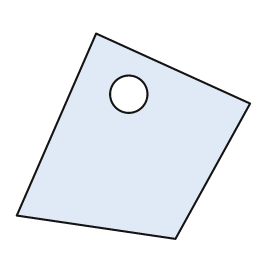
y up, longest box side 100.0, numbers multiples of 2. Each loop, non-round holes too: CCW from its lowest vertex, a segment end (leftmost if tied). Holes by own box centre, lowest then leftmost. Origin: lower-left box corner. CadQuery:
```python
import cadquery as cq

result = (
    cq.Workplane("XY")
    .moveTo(68.0, 0.0)
    .lineTo(100.0, 58.0)
    .lineTo(34.0, 88.0)
    .lineTo(0.0, 10.0)
    .close()
    .moveTo(48.0, 62.0)
    .circle(8.0)
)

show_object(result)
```